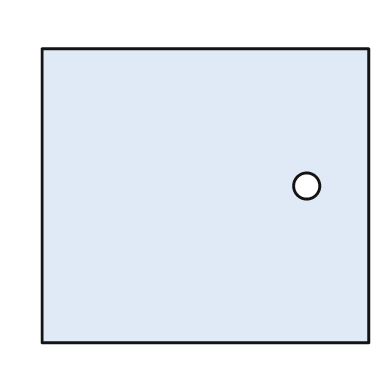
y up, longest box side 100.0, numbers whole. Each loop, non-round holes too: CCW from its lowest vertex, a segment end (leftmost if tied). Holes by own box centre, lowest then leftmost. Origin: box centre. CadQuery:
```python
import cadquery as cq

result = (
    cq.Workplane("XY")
    .moveTo(-50.0, -45.0)
    .lineTo(50.0, -45.0)
    .lineTo(50.0, 45.0)
    .lineTo(-50.0, 45.0)
    .close()
    .moveTo(31.0, 3.0)
    .circle(4.0)
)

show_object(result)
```